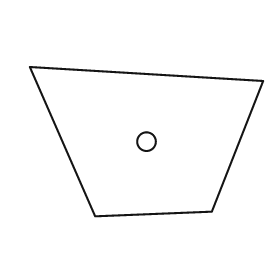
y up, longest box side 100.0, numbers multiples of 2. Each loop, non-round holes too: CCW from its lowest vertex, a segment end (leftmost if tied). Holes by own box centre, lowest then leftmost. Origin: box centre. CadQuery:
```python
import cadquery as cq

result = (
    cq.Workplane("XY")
    .moveTo(-22.0, -32.0)
    .lineTo(28.0, -30.0)
    .lineTo(50.0, 26.0)
    .lineTo(-50.0, 32.0)
    .close()
    .moveTo(0.0, 0.0)
    .circle(4.0)
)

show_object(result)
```